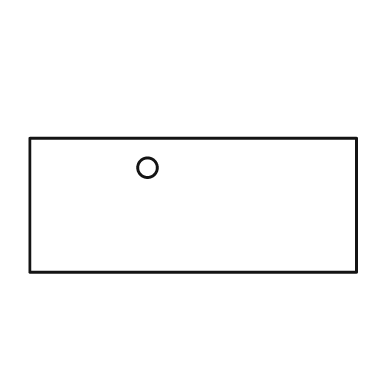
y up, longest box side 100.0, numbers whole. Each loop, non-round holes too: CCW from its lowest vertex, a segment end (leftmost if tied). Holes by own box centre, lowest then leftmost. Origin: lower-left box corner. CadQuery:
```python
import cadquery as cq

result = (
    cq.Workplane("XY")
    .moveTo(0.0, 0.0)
    .lineTo(100.0, 0.0)
    .lineTo(100.0, 41.0)
    .lineTo(0.0, 41.0)
    .close()
    .moveTo(36.0, 32.0)
    .circle(3.0)
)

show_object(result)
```